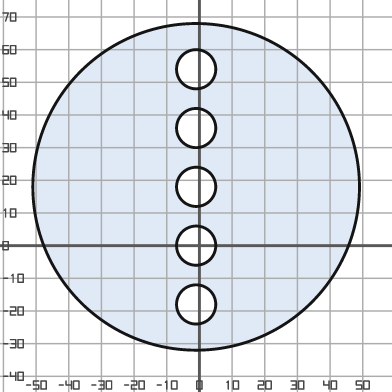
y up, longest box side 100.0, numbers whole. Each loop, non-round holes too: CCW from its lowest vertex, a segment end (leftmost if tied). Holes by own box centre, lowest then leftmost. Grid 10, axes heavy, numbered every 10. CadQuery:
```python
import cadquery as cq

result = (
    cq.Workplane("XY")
    .moveTo(-1.0, 18.0)
    .circle(50.0)
    .moveTo(-1.0, -18.0)
    .circle(6.0)
    .moveTo(-1.0, 0.0)
    .circle(6.0)
    .moveTo(-1.0, 18.0)
    .circle(6.0)
    .moveTo(-1.0, 36.0)
    .circle(6.0)
    .moveTo(-1.0, 54.0)
    .circle(6.0)
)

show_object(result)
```